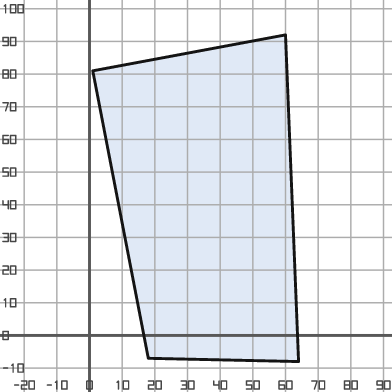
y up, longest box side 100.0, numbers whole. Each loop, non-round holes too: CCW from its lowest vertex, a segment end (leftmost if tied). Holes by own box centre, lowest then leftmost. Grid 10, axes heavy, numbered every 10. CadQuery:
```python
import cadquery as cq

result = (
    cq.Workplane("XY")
    .moveTo(64.0, -8.0)
    .lineTo(60.0, 92.0)
    .lineTo(1.0, 81.0)
    .lineTo(18.0, -7.0)
    .close()
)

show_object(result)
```